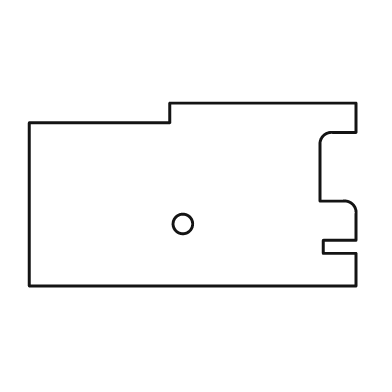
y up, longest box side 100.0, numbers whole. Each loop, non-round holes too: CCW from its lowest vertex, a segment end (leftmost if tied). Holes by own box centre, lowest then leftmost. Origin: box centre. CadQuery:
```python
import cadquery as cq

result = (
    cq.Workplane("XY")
    .moveTo(-50.0, -28.0)
    .lineTo(50.0, -28.0)
    .lineTo(50.0, -18.0)
    .lineTo(40.0, -18.0)
    .lineTo(40.0, -14.0)
    .lineTo(50.0, -14.0)
    .lineTo(50.0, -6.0)
    .threePointArc((49.0, -3.0), (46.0, -2.0))
    .lineTo(39.0, -2.0)
    .lineTo(39.0, 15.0)
    .threePointArc((40.0, 18.0), (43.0, 19.0))
    .lineTo(50.0, 19.0)
    .lineTo(50.0, 28.0)
    .lineTo(-7.0, 28.0)
    .lineTo(-7.0, 22.0)
    .lineTo(-50.0, 22.0)
    .close()
    .moveTo(-3.0, -9.0)
    .circle(3.0)
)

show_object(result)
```